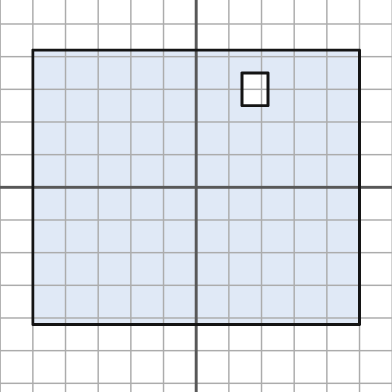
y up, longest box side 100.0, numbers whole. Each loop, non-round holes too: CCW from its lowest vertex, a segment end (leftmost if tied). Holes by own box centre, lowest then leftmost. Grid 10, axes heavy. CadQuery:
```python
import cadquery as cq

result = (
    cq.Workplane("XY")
    .moveTo(-50.0, -42.0)
    .lineTo(50.0, -42.0)
    .lineTo(50.0, 42.0)
    .lineTo(-50.0, 42.0)
    .close()
    .moveTo(14.0, 25.0)
    .lineTo(22.0, 25.0)
    .lineTo(22.0, 35.0)
    .lineTo(14.0, 35.0)
    .close()
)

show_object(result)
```